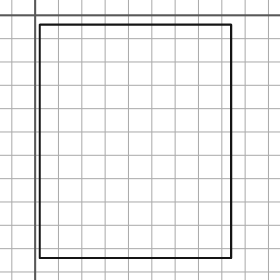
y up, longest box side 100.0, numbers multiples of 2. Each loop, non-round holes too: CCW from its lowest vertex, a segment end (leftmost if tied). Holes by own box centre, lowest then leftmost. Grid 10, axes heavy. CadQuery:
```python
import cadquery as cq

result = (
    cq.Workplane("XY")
    .moveTo(2.0, -104.0)
    .lineTo(84.0, -104.0)
    .lineTo(84.0, -4.0)
    .lineTo(2.0, -4.0)
    .close()
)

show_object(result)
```